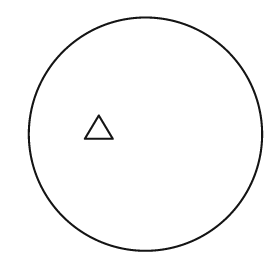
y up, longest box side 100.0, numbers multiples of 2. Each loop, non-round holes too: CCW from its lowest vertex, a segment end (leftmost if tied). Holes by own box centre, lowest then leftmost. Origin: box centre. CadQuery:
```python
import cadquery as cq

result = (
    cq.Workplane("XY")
    .moveTo(0.0, 0.0)
    .circle(50.0)
    .moveTo(-26.0, -2.0)
    .lineTo(-14.0, -2.0)
    .lineTo(-20.0, 8.0)
    .close()
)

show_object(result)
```